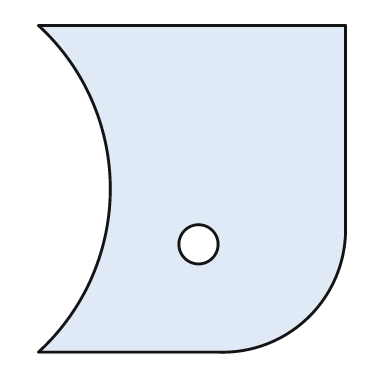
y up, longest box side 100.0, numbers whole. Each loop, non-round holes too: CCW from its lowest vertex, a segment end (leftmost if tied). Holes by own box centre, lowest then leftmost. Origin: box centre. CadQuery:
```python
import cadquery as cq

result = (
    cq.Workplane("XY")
    .moveTo(-47.0, -50.0)
    .lineTo(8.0, -50.0)
    .threePointArc((36.0, -39.0), (47.0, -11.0))
    .lineTo(47.0, 50.0)
    .lineTo(-47.0, 50.0)
    .threePointArc((-25.0, 0.0), (-47.0, -50.0))
    .close()
    .moveTo(2.0, -17.0)
    .circle(6.0)
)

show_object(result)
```